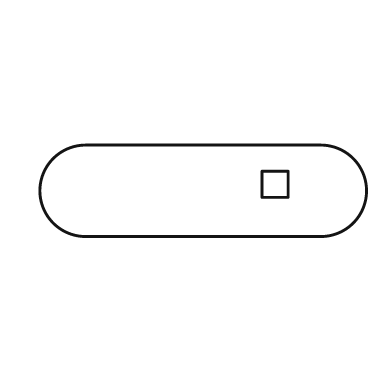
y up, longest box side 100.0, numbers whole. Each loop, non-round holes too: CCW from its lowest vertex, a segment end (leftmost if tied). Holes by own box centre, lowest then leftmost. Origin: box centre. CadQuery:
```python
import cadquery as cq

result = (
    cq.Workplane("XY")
    .moveTo(-36.0, -14.0)
    .lineTo(36.0, -14.0)
    .threePointArc((50.0, 0.0), (36.0, 14.0))
    .lineTo(-36.0, 14.0)
    .threePointArc((-50.0, 0.0), (-36.0, -14.0))
    .close()
    .moveTo(18.0, -2.0)
    .lineTo(26.0, -2.0)
    .lineTo(26.0, 6.0)
    .lineTo(18.0, 6.0)
    .close()
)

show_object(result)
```